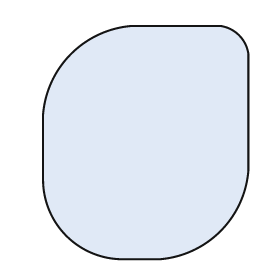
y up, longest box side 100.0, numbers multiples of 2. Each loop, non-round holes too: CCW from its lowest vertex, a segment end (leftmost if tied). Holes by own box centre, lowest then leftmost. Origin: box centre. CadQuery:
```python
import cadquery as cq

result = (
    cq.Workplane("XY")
    .moveTo(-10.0, -50.0)
    .lineTo(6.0, -50.0)
    .threePointArc((32.0, -38.0), (44.0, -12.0))
    .lineTo(44.0, 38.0)
    .threePointArc((40.0, 46.0), (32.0, 50.0))
    .lineTo(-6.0, 50.0)
    .threePointArc((-32.0, 38.0), (-44.0, 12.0))
    .lineTo(-44.0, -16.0)
    .threePointArc((-34.0, -40.0), (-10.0, -50.0))
    .close()
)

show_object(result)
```